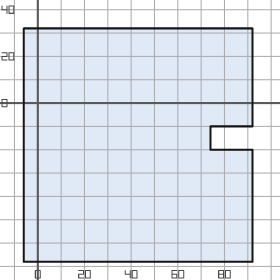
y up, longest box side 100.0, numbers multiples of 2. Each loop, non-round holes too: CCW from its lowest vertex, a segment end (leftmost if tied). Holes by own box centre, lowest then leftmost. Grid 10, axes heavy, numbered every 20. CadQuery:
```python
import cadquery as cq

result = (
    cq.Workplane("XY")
    .moveTo(-6.0, -68.0)
    .lineTo(92.0, -68.0)
    .lineTo(92.0, -20.0)
    .lineTo(74.0, -20.0)
    .lineTo(74.0, -10.0)
    .lineTo(92.0, -10.0)
    .lineTo(92.0, 32.0)
    .lineTo(-6.0, 32.0)
    .close()
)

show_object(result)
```